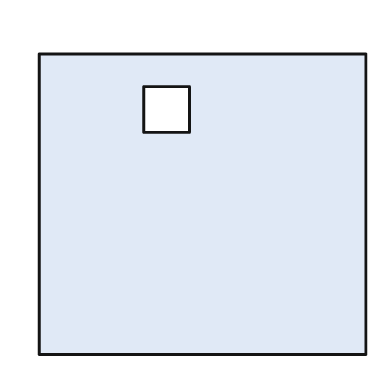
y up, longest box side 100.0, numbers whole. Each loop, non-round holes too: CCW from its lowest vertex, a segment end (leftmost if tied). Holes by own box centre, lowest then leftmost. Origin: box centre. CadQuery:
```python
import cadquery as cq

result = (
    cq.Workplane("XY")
    .moveTo(-50.0, -46.0)
    .lineTo(50.0, -46.0)
    .lineTo(50.0, 46.0)
    .lineTo(-50.0, 46.0)
    .close()
    .moveTo(-18.0, 22.0)
    .lineTo(-4.0, 22.0)
    .lineTo(-4.0, 36.0)
    .lineTo(-18.0, 36.0)
    .close()
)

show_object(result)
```